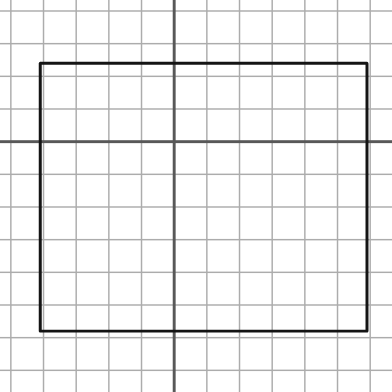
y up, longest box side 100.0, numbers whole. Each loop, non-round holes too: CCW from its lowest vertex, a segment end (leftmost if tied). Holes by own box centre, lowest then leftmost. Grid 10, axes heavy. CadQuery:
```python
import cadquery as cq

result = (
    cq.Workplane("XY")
    .moveTo(-41.0, -58.0)
    .lineTo(59.0, -58.0)
    .lineTo(59.0, 24.0)
    .lineTo(-41.0, 24.0)
    .close()
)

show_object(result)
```